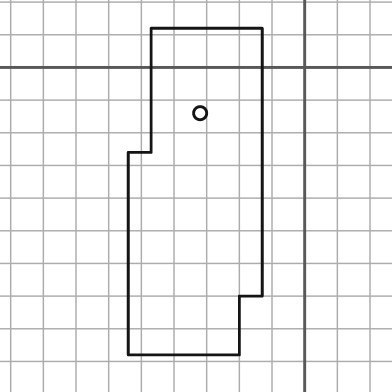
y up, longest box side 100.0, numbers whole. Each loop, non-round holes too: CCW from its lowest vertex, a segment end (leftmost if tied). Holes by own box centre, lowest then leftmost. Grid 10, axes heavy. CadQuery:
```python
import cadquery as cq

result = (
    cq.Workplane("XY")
    .moveTo(-54.0, -88.0)
    .lineTo(-20.0, -88.0)
    .lineTo(-20.0, -70.0)
    .lineTo(-13.0, -70.0)
    .lineTo(-13.0, 12.0)
    .lineTo(-47.0, 12.0)
    .lineTo(-47.0, -26.0)
    .lineTo(-54.0, -26.0)
    .close()
    .moveTo(-32.0, -14.0)
    .circle(2.0)
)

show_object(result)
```